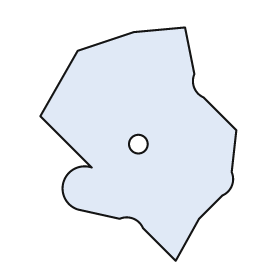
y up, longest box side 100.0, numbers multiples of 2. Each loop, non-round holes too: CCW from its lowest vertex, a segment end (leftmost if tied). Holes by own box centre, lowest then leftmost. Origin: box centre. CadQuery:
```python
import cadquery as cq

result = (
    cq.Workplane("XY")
    .moveTo(16.0, -50.0)
    .lineTo(26.0, -32.0)
    .lineTo(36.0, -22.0)
    .threePointArc((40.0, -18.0), (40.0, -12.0))
    .lineTo(42.0, 6.0)
    .lineTo(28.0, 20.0)
    .threePointArc((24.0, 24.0), (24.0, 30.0))
    .lineTo(20.0, 50.0)
    .lineTo(-2.0, 48.0)
    .lineTo(-26.0, 40.0)
    .lineTo(-42.0, 12.0)
    .lineTo(-20.0, -10.0)
    .threePointArc((-32.0, -16.0), (-26.0, -28.0))
    .lineTo(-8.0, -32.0)
    .threePointArc((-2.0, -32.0), (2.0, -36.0))
    .close()
    .moveTo(0.0, 0.0)
    .circle(4.0)
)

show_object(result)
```